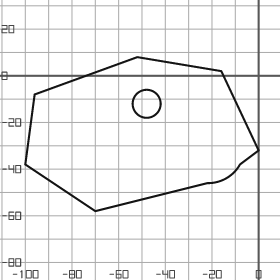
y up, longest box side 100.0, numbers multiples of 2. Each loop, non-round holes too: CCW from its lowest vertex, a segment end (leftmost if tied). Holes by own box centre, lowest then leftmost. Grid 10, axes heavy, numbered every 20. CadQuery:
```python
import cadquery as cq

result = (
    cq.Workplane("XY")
    .moveTo(-70.0, -58.0)
    .lineTo(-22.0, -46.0)
    .threePointArc((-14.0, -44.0), (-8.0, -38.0))
    .lineTo(0.0, -32.0)
    .lineTo(-16.0, 2.0)
    .lineTo(-52.0, 8.0)
    .lineTo(-96.0, -8.0)
    .lineTo(-100.0, -38.0)
    .close()
    .moveTo(-48.0, -12.0)
    .circle(6.0)
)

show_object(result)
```